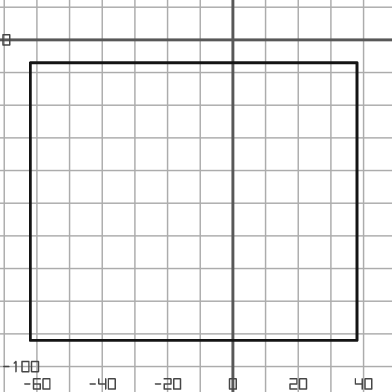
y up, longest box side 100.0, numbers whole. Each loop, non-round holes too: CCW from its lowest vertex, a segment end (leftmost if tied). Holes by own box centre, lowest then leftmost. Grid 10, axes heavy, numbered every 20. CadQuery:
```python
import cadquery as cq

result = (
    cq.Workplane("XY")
    .moveTo(-62.0, -92.0)
    .lineTo(38.0, -92.0)
    .lineTo(38.0, -7.0)
    .lineTo(-62.0, -7.0)
    .close()
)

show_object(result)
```